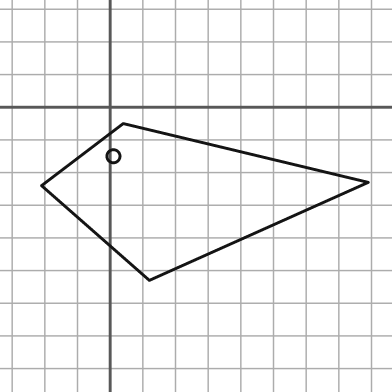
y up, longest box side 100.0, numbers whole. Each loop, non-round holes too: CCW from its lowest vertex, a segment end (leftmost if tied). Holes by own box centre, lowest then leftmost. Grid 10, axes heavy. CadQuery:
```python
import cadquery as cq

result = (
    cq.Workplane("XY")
    .moveTo(12.0, -53.0)
    .lineTo(79.0, -23.0)
    .lineTo(4.0, -5.0)
    .lineTo(-21.0, -24.0)
    .close()
    .moveTo(1.0, -15.0)
    .circle(2.0)
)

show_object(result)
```